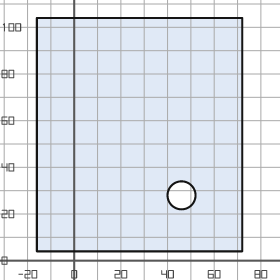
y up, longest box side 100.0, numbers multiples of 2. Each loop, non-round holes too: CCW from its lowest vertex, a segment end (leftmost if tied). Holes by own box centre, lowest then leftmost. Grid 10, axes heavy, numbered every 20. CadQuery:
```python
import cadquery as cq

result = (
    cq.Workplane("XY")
    .moveTo(-16.0, 4.0)
    .lineTo(72.0, 4.0)
    .lineTo(72.0, 104.0)
    .lineTo(-16.0, 104.0)
    .close()
    .moveTo(46.0, 28.0)
    .circle(6.0)
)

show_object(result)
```